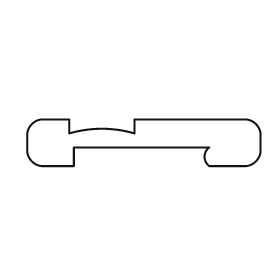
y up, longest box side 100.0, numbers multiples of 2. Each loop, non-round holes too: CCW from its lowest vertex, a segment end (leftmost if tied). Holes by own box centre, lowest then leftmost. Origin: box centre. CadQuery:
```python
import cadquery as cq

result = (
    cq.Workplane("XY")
    .moveTo(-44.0, -10.0)
    .lineTo(-30.0, -10.0)
    .lineTo(-30.0, -2.0)
    .lineTo(28.0, -2.0)
    .threePointArc((26.0, -6.0), (28.0, -10.0))
    .lineTo(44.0, -10.0)
    .threePointArc((48.0, -8.0), (50.0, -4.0))
    .lineTo(50.0, 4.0)
    .threePointArc((48.0, 8.0), (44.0, 10.0))
    .lineTo(-4.0, 10.0)
    .lineTo(-4.0, 4.0)
    .threePointArc((-18.0, 6.0), (-32.0, 4.0))
    .lineTo(-32.0, 10.0)
    .lineTo(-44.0, 10.0)
    .threePointArc((-48.0, 8.0), (-50.0, 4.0))
    .lineTo(-50.0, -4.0)
    .threePointArc((-48.0, -8.0), (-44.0, -10.0))
    .close()
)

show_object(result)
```